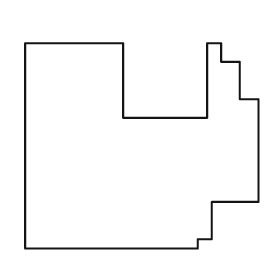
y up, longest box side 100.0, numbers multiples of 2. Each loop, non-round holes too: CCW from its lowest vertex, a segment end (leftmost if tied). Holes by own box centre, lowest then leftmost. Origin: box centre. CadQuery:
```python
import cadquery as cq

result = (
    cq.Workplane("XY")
    .moveTo(-50.0, -44.0)
    .lineTo(24.0, -44.0)
    .lineTo(24.0, -40.0)
    .lineTo(30.0, -40.0)
    .lineTo(30.0, -24.0)
    .lineTo(50.0, -24.0)
    .lineTo(50.0, 20.0)
    .lineTo(42.0, 20.0)
    .lineTo(42.0, 36.0)
    .lineTo(34.0, 36.0)
    .lineTo(34.0, 44.0)
    .lineTo(28.0, 44.0)
    .lineTo(28.0, 12.0)
    .lineTo(-8.0, 12.0)
    .lineTo(-8.0, 44.0)
    .lineTo(-50.0, 44.0)
    .close()
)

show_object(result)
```